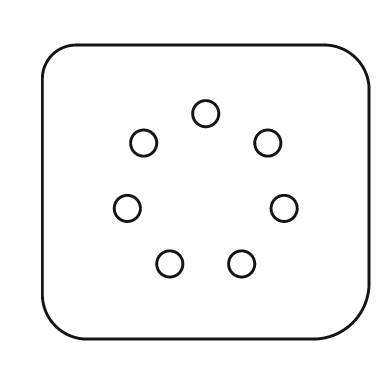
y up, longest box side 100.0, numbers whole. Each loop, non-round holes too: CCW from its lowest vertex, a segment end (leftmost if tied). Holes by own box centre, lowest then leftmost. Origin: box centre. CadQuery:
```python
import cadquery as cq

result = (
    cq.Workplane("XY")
    .moveTo(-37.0, -45.0)
    .lineTo(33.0, -45.0)
    .threePointArc((45.0, -40.0), (50.0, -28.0))
    .lineTo(50.0, 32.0)
    .threePointArc((46.0, 41.0), (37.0, 45.0))
    .lineTo(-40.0, 45.0)
    .threePointArc((-47.0, 42.0), (-50.0, 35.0))
    .lineTo(-50.0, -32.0)
    .threePointArc((-46.0, -41.0), (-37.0, -45.0))
    .close()
    .moveTo(-11.0, -22.0)
    .circle(4.0)
    .moveTo(11.0, -22.0)
    .circle(4.0)
    .moveTo(-24.0, -5.0)
    .circle(4.0)
    .moveTo(24.0, -5.0)
    .circle(4.0)
    .moveTo(-19.0, 15.0)
    .circle(4.0)
    .moveTo(19.0, 15.0)
    .circle(4.0)
    .moveTo(0.0, 24.0)
    .circle(4.0)
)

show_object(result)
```